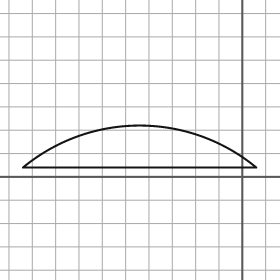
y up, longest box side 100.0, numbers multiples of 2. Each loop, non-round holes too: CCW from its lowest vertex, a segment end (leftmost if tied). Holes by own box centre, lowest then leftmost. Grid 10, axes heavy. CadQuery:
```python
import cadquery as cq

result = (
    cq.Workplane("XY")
    .moveTo(-94.0, 4.0)
    .lineTo(6.0, 4.0)
    .threePointArc((-44.0, 22.0), (-94.0, 4.0))
    .close()
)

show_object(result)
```